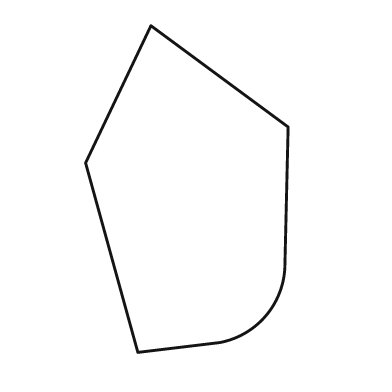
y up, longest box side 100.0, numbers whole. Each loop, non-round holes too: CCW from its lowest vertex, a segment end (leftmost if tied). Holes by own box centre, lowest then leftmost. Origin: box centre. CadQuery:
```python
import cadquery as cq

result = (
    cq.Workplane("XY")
    .moveTo(-15.0, -50.0)
    .lineTo(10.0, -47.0)
    .threePointArc((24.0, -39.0), (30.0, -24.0))
    .lineTo(31.0, 19.0)
    .lineTo(-11.0, 50.0)
    .lineTo(-31.0, 8.0)
    .close()
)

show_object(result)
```